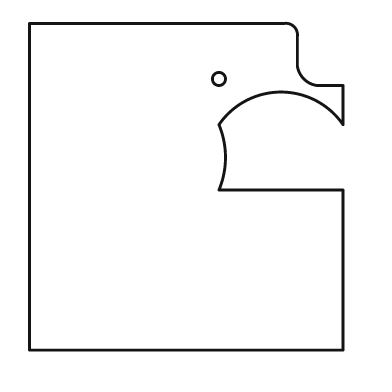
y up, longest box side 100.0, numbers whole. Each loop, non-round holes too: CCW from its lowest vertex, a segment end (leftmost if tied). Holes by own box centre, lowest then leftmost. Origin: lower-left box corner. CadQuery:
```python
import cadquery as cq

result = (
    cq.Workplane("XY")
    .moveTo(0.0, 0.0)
    .lineTo(96.0, 0.0)
    .lineTo(96.0, 49.0)
    .lineTo(58.0, 49.0)
    .threePointArc((60.0, 59.0), (58.0, 69.0))
    .threePointArc((77.0, 79.0), (96.0, 69.0))
    .lineTo(96.0, 81.0)
    .lineTo(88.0, 81.0)
    .threePointArc((84.0, 83.0), (82.0, 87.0))
    .lineTo(82.0, 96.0)
    .threePointArc((81.0, 99.0), (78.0, 100.0))
    .lineTo(0.0, 100.0)
    .close()
    .moveTo(58.0, 83.0)
    .circle(2.0)
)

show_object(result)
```